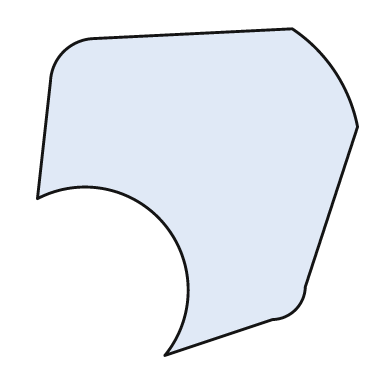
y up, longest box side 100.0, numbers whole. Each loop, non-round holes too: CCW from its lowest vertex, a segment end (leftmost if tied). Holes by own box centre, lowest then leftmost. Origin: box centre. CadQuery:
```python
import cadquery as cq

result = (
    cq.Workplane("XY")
    .moveTo(-10.0, -50.0)
    .lineTo(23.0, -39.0)
    .threePointArc((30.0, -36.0), (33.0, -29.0))
    .lineTo(49.0, 20.0)
    .threePointArc((42.0, 37.0), (29.0, 50.0))
    .lineTo(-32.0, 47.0)
    .threePointArc((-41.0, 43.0), (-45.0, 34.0))
    .lineTo(-49.0, -2.0)
    .threePointArc((-10.0, -10.0), (-10.0, -50.0))
    .close()
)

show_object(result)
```